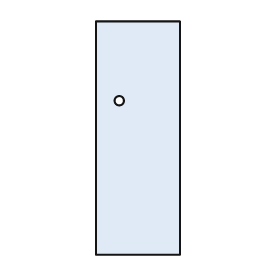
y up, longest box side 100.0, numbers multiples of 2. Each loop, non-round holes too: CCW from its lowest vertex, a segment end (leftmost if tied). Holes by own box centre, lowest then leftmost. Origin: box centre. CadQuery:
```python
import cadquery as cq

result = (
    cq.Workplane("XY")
    .moveTo(-18.0, -50.0)
    .lineTo(18.0, -50.0)
    .lineTo(18.0, 50.0)
    .lineTo(-18.0, 50.0)
    .close()
    .moveTo(-8.0, 16.0)
    .circle(2.0)
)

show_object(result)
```